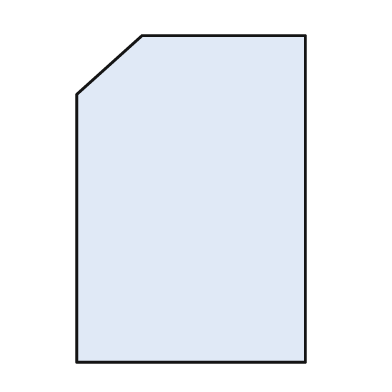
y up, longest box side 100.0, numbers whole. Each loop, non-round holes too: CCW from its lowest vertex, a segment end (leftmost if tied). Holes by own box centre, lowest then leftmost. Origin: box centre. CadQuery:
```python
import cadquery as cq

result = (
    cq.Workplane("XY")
    .moveTo(-35.0, -50.0)
    .lineTo(35.0, -50.0)
    .lineTo(35.0, 50.0)
    .lineTo(-15.0, 50.0)
    .lineTo(-35.0, 32.0)
    .close()
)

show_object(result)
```